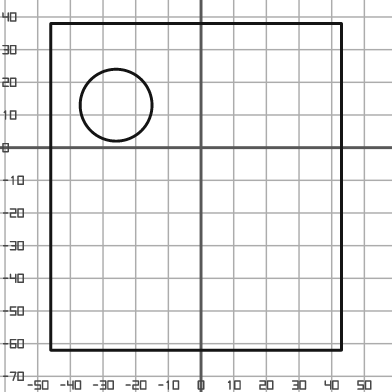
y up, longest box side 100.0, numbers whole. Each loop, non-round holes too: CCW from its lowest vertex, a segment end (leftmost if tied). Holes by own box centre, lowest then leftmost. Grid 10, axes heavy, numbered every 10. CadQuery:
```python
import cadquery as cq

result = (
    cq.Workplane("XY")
    .moveTo(-46.0, -62.0)
    .lineTo(43.0, -62.0)
    .lineTo(43.0, 38.0)
    .lineTo(-46.0, 38.0)
    .close()
    .moveTo(-26.0, 13.0)
    .circle(11.0)
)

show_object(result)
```